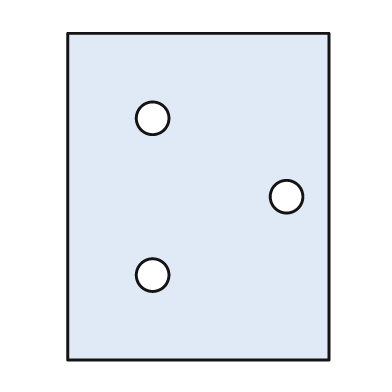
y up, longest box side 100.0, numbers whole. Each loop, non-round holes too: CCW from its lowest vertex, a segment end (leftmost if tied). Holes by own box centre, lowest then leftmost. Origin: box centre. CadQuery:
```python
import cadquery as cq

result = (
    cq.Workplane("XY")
    .moveTo(-40.0, -50.0)
    .lineTo(40.0, -50.0)
    .lineTo(40.0, 50.0)
    .lineTo(-40.0, 50.0)
    .close()
    .moveTo(-14.0, -24.0)
    .circle(5.0)
    .moveTo(27.0, 0.0)
    .circle(5.0)
    .moveTo(-14.0, 24.0)
    .circle(5.0)
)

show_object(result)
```